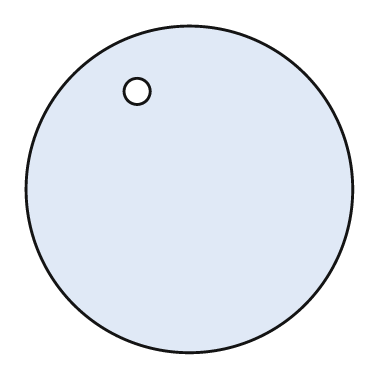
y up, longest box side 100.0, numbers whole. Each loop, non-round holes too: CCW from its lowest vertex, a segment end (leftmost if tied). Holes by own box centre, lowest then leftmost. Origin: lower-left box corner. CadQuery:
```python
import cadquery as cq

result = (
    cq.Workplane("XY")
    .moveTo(50.0, 50.0)
    .circle(50.0)
    .moveTo(34.0, 80.0)
    .circle(4.0)
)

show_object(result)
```